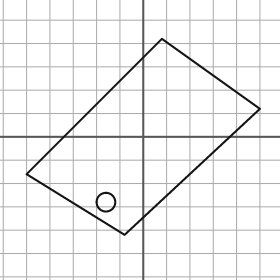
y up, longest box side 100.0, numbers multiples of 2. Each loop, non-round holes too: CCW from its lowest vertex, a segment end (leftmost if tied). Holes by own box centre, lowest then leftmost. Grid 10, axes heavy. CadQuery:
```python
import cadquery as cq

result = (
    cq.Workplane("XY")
    .moveTo(-8.0, -42.0)
    .lineTo(50.0, 12.0)
    .lineTo(8.0, 42.0)
    .lineTo(-50.0, -16.0)
    .close()
    .moveTo(-16.0, -28.0)
    .circle(4.0)
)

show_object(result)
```